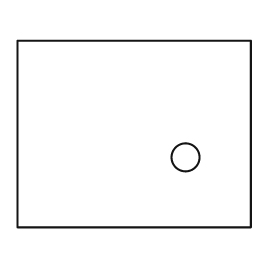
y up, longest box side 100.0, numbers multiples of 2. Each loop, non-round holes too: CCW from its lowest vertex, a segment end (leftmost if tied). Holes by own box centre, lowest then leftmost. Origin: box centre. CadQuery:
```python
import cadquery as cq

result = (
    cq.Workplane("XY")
    .moveTo(-50.0, -40.0)
    .lineTo(50.0, -40.0)
    .lineTo(50.0, 40.0)
    .lineTo(-50.0, 40.0)
    .close()
    .moveTo(22.0, -10.0)
    .circle(6.0)
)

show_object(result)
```